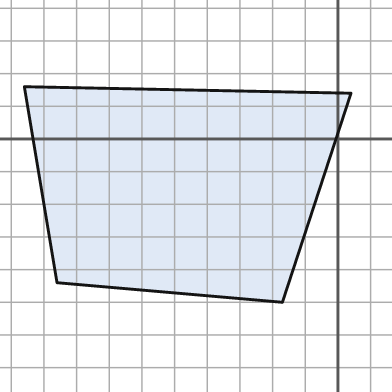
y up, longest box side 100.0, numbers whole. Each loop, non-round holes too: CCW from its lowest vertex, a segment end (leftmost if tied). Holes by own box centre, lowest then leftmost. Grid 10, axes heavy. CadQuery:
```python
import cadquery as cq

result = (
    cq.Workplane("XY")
    .moveTo(-17.0, -50.0)
    .lineTo(4.0, 14.0)
    .lineTo(-96.0, 16.0)
    .lineTo(-86.0, -44.0)
    .close()
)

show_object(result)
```